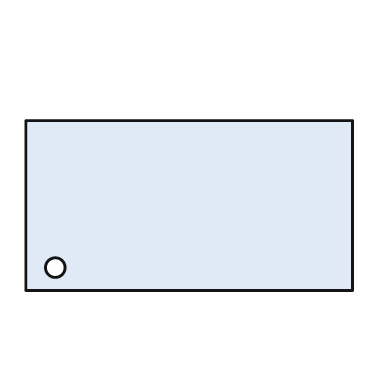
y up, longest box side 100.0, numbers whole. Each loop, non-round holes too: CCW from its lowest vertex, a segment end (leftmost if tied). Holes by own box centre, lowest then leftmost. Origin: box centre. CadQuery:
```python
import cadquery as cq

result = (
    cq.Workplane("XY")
    .moveTo(-50.0, -26.0)
    .lineTo(50.0, -26.0)
    .lineTo(50.0, 26.0)
    .lineTo(-50.0, 26.0)
    .close()
    .moveTo(-41.0, -19.0)
    .circle(3.0)
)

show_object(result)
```